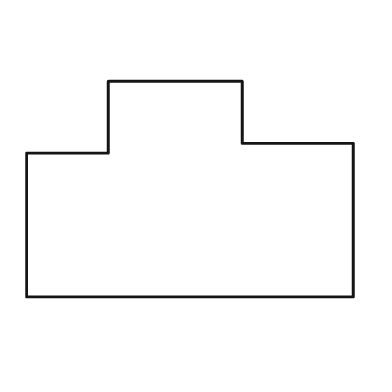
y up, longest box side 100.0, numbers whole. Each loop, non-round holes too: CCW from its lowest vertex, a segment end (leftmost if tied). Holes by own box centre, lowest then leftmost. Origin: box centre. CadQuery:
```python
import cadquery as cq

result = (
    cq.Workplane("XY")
    .moveTo(-50.0, -33.0)
    .lineTo(50.0, -33.0)
    .lineTo(50.0, 14.0)
    .lineTo(16.0, 14.0)
    .lineTo(16.0, 33.0)
    .lineTo(-25.0, 33.0)
    .lineTo(-25.0, 11.0)
    .lineTo(-50.0, 11.0)
    .close()
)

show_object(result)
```